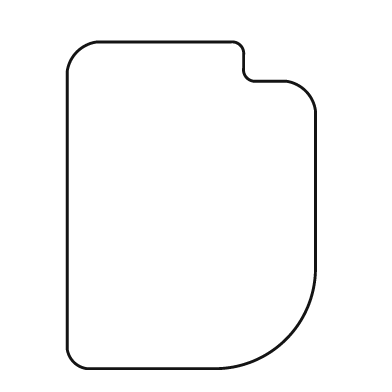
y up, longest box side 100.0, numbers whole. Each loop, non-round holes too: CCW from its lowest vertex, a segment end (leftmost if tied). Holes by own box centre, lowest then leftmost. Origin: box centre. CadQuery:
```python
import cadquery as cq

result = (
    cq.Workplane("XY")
    .moveTo(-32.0, -50.0)
    .lineTo(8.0, -50.0)
    .threePointArc((29.0, -41.0), (38.0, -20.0))
    .lineTo(38.0, 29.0)
    .threePointArc((35.0, 35.0), (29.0, 38.0))
    .lineTo(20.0, 38.0)
    .threePointArc((17.0, 39.0), (16.0, 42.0))
    .lineTo(16.0, 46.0)
    .threePointArc((15.0, 49.0), (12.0, 50.0))
    .lineTo(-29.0, 50.0)
    .threePointArc((-35.0, 47.0), (-38.0, 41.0))
    .lineTo(-38.0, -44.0)
    .threePointArc((-36.0, -48.0), (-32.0, -50.0))
    .close()
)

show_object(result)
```